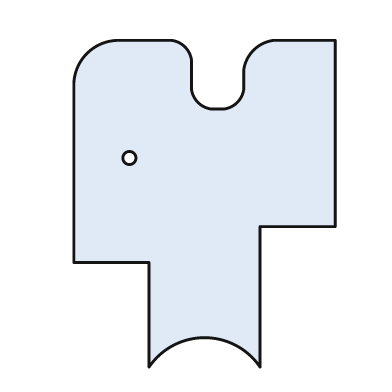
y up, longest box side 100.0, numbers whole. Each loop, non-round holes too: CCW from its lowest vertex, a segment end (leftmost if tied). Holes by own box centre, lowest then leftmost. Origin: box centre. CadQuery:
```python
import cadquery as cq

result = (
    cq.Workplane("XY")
    .moveTo(-17.0, -50.0)
    .threePointArc((0.0, -41.0), (17.0, -50.0))
    .lineTo(17.0, -7.0)
    .lineTo(40.0, -7.0)
    .lineTo(40.0, 50.0)
    .lineTo(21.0, 50.0)
    .threePointArc((15.0, 47.0), (12.0, 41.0))
    .lineTo(12.0, 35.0)
    .threePointArc((10.0, 31.0), (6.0, 29.0))
    .lineTo(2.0, 29.0)
    .threePointArc((-2.0, 31.0), (-4.0, 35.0))
    .lineTo(-4.0, 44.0)
    .threePointArc((-6.0, 48.0), (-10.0, 50.0))
    .lineTo(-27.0, 50.0)
    .threePointArc((-36.0, 46.0), (-40.0, 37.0))
    .lineTo(-40.0, -18.0)
    .lineTo(-17.0, -18.0)
    .close()
    .moveTo(-23.0, 14.0)
    .circle(2.0)
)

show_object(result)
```